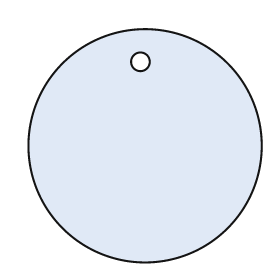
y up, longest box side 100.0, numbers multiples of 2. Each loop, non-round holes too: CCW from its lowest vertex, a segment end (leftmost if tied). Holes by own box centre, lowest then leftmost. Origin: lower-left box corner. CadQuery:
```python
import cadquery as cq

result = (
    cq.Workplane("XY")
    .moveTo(50.0, 50.0)
    .circle(50.0)
    .moveTo(48.0, 86.0)
    .circle(4.0)
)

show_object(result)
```